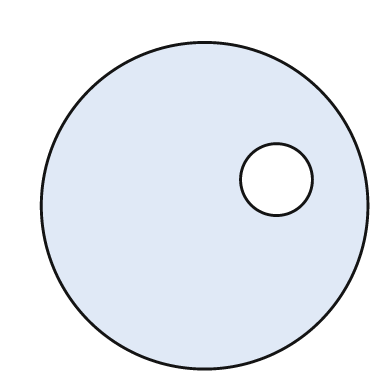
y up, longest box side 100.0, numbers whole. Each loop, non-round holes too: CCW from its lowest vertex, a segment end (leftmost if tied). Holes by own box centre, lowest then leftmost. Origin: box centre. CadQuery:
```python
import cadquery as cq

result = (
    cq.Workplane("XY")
    .moveTo(0.0, 0.0)
    .circle(50.0)
    .moveTo(22.0, 8.0)
    .circle(11.0)
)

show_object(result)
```